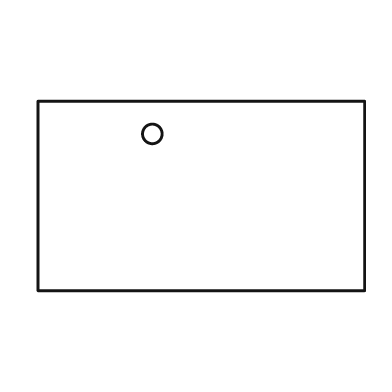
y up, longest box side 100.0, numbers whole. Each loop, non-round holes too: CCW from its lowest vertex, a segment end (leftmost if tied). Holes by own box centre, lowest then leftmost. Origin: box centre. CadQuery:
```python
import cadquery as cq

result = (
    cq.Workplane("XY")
    .moveTo(-50.0, -29.0)
    .lineTo(50.0, -29.0)
    .lineTo(50.0, 29.0)
    .lineTo(-50.0, 29.0)
    .close()
    .moveTo(-15.0, 19.0)
    .circle(3.0)
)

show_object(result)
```